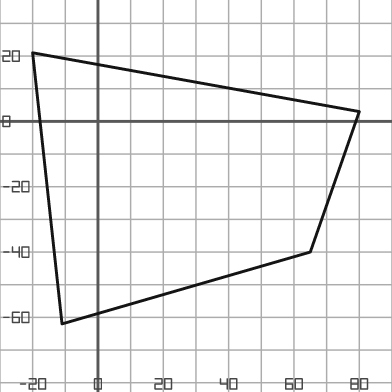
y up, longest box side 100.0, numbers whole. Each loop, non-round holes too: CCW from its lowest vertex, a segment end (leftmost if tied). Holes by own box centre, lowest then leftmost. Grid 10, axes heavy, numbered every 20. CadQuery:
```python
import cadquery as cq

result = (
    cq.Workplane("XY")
    .moveTo(-11.0, -62.0)
    .lineTo(65.0, -40.0)
    .lineTo(80.0, 3.0)
    .lineTo(-20.0, 21.0)
    .close()
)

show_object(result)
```